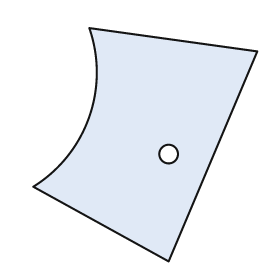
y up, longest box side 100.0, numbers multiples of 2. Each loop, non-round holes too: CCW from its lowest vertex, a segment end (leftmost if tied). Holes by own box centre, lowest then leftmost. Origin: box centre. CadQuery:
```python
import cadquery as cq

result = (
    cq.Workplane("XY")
    .moveTo(10.0, -50.0)
    .lineTo(48.0, 40.0)
    .lineTo(-24.0, 50.0)
    .threePointArc((-24.0, 12.0), (-48.0, -18.0))
    .close()
    .moveTo(10.0, -4.0)
    .circle(4.0)
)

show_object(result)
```